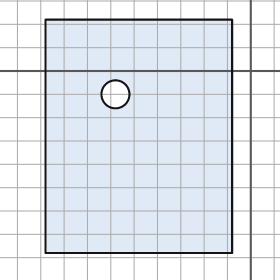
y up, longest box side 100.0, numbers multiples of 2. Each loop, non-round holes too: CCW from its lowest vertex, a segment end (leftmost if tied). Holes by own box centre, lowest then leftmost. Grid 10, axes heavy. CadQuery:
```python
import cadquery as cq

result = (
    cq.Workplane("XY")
    .moveTo(-88.0, -78.0)
    .lineTo(-8.0, -78.0)
    .lineTo(-8.0, 22.0)
    .lineTo(-88.0, 22.0)
    .close()
    .moveTo(-58.0, -10.0)
    .circle(6.0)
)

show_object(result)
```